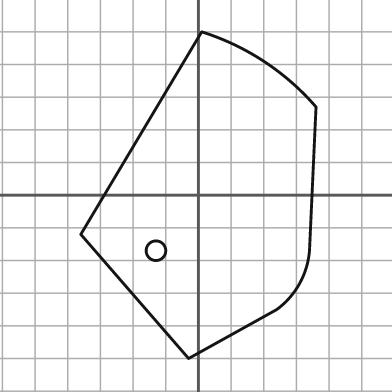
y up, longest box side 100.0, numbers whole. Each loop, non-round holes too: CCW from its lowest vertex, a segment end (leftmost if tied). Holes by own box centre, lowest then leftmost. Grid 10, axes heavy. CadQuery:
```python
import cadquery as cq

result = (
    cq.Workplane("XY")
    .moveTo(-3.0, -50.0)
    .lineTo(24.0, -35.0)
    .threePointArc((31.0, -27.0), (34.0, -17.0))
    .lineTo(36.0, 27.0)
    .threePointArc((20.0, 41.0), (1.0, 50.0))
    .lineTo(-36.0, -12.0)
    .close()
    .moveTo(-13.0, -17.0)
    .circle(3.0)
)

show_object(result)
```